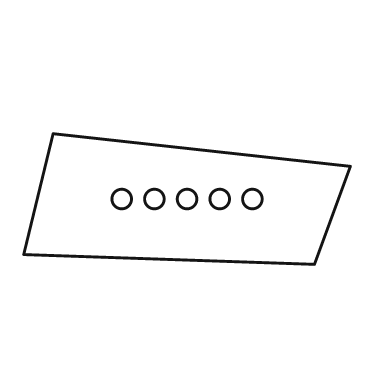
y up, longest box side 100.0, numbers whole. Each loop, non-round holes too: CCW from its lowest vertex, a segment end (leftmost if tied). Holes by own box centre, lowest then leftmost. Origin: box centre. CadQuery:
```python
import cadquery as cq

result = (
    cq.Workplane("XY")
    .moveTo(39.0, -20.0)
    .lineTo(50.0, 10.0)
    .lineTo(-41.0, 20.0)
    .lineTo(-50.0, -17.0)
    .close()
    .moveTo(-20.0, 0.0)
    .circle(3.0)
    .moveTo(-10.0, 0.0)
    .circle(3.0)
    .moveTo(0.0, 0.0)
    .circle(3.0)
    .moveTo(10.0, 0.0)
    .circle(3.0)
    .moveTo(20.0, 0.0)
    .circle(3.0)
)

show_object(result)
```